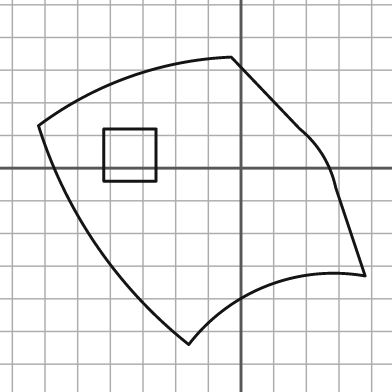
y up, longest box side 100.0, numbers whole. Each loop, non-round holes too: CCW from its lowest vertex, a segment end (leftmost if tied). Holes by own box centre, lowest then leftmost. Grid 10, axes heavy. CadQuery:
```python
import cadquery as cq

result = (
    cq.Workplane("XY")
    .moveTo(-16.0, -54.0)
    .threePointArc((8.0, -36.0), (38.0, -33.0))
    .lineTo(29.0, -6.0)
    .threePointArc((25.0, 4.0), (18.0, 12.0))
    .lineTo(-3.0, 34.0)
    .threePointArc((-34.0, 28.0), (-62.0, 13.0))
    .threePointArc((-44.0, -24.0), (-16.0, -54.0))
    .close()
    .moveTo(-42.0, -4.0)
    .lineTo(-26.0, -4.0)
    .lineTo(-26.0, 12.0)
    .lineTo(-42.0, 12.0)
    .close()
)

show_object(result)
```